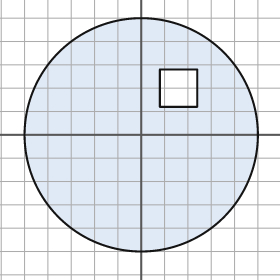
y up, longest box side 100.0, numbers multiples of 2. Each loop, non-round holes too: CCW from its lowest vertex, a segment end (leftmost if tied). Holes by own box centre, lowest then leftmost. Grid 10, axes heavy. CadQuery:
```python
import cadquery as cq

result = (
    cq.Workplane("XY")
    .moveTo(0.0, 0.0)
    .circle(50.0)
    .moveTo(8.0, 12.0)
    .lineTo(24.0, 12.0)
    .lineTo(24.0, 28.0)
    .lineTo(8.0, 28.0)
    .close()
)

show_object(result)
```